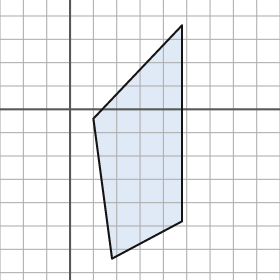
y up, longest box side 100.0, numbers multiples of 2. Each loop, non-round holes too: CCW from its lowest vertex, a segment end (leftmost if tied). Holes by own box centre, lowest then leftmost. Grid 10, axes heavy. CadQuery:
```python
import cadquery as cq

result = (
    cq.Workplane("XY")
    .moveTo(18.0, -64.0)
    .lineTo(48.0, -48.0)
    .lineTo(48.0, 36.0)
    .lineTo(10.0, -4.0)
    .close()
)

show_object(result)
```